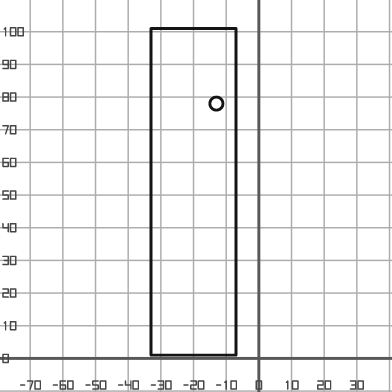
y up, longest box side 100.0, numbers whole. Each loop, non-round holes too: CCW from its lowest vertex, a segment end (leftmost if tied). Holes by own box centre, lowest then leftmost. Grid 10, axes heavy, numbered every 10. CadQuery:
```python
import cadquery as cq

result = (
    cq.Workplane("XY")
    .moveTo(-33.0, 1.0)
    .lineTo(-7.0, 1.0)
    .lineTo(-7.0, 101.0)
    .lineTo(-33.0, 101.0)
    .close()
    .moveTo(-13.0, 78.0)
    .circle(2.0)
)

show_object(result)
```